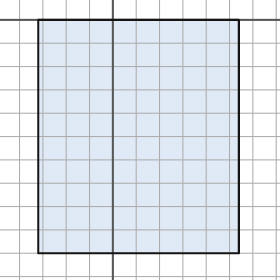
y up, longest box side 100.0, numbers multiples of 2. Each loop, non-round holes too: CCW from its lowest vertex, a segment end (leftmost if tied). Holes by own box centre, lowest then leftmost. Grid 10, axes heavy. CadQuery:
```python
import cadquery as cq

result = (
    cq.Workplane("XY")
    .moveTo(-32.0, -100.0)
    .lineTo(54.0, -100.0)
    .lineTo(54.0, 0.0)
    .lineTo(-32.0, 0.0)
    .close()
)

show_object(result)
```